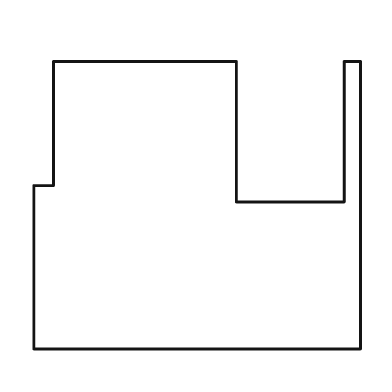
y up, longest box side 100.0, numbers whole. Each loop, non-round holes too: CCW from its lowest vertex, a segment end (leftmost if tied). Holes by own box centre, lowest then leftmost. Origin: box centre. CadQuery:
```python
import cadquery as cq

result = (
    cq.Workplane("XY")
    .moveTo(-50.0, -44.0)
    .lineTo(50.0, -44.0)
    .lineTo(50.0, 44.0)
    .lineTo(45.0, 44.0)
    .lineTo(45.0, 1.0)
    .lineTo(12.0, 1.0)
    .lineTo(12.0, 44.0)
    .lineTo(-44.0, 44.0)
    .lineTo(-44.0, 6.0)
    .lineTo(-50.0, 6.0)
    .close()
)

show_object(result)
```